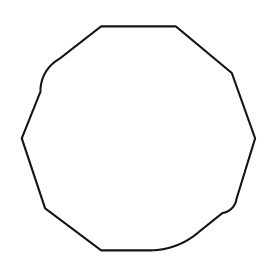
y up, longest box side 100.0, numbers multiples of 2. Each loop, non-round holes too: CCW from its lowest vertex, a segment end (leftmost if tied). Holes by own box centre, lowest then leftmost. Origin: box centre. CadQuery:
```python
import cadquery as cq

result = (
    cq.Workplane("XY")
    .moveTo(-16.0, -48.0)
    .lineTo(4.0, -48.0)
    .threePointArc((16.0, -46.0), (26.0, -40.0))
    .lineTo(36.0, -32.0)
    .threePointArc((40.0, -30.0), (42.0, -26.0))
    .lineTo(50.0, 0.0)
    .lineTo(40.0, 28.0)
    .lineTo(16.0, 48.0)
    .lineTo(-16.0, 48.0)
    .lineTo(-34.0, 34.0)
    .threePointArc((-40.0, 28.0), (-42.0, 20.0))
    .lineTo(-50.0, 0.0)
    .lineTo(-40.0, -30.0)
    .close()
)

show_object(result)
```